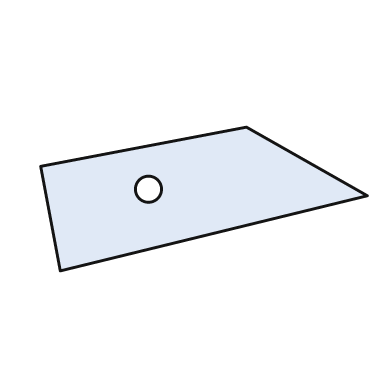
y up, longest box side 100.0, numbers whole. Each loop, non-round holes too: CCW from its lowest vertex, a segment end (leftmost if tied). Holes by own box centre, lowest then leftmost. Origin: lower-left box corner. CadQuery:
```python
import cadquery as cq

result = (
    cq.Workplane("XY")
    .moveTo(6.0, 0.0)
    .lineTo(100.0, 23.0)
    .lineTo(63.0, 44.0)
    .lineTo(0.0, 32.0)
    .close()
    .moveTo(33.0, 25.0)
    .circle(4.0)
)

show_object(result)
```